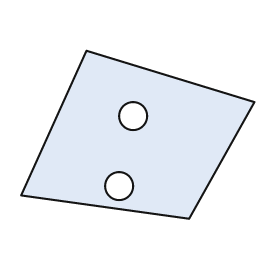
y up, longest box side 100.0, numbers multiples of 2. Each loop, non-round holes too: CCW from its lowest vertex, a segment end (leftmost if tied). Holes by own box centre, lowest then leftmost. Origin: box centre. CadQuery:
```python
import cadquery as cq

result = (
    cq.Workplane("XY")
    .moveTo(22.0, -36.0)
    .lineTo(50.0, 14.0)
    .lineTo(-22.0, 36.0)
    .lineTo(-50.0, -26.0)
    .close()
    .moveTo(-8.0, -22.0)
    .circle(6.0)
    .moveTo(-2.0, 8.0)
    .circle(6.0)
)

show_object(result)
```